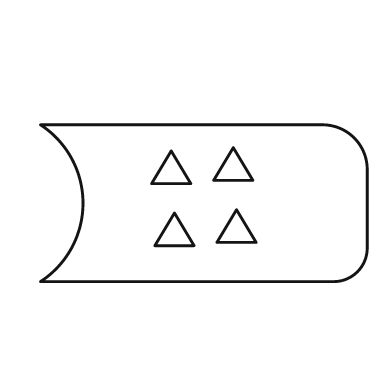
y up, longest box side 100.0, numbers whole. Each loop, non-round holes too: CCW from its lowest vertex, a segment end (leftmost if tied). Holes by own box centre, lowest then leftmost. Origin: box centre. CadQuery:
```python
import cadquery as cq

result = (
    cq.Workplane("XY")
    .moveTo(-50.0, -24.0)
    .lineTo(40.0, -24.0)
    .threePointArc((47.0, -21.0), (50.0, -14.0))
    .lineTo(50.0, 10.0)
    .threePointArc((46.0, 20.0), (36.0, 24.0))
    .lineTo(-50.0, 24.0)
    .threePointArc((-37.0, 0.0), (-50.0, -24.0))
    .close()
    .moveTo(-15.0, -13.0)
    .lineTo(-3.0, -13.0)
    .lineTo(-9.0, -3.0)
    .close()
    .moveTo(4.0, -12.0)
    .lineTo(16.0, -12.0)
    .lineTo(10.0, -2.0)
    .close()
    .moveTo(-16.0, 6.0)
    .lineTo(-4.0, 6.0)
    .lineTo(-10.0, 16.0)
    .close()
    .moveTo(3.0, 7.0)
    .lineTo(15.0, 7.0)
    .lineTo(9.0, 17.0)
    .close()
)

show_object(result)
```